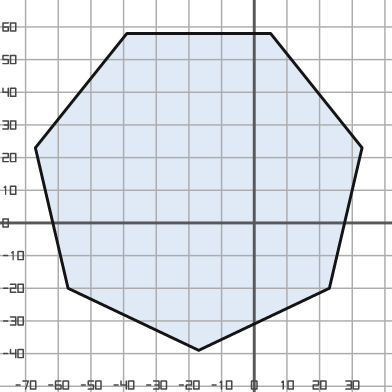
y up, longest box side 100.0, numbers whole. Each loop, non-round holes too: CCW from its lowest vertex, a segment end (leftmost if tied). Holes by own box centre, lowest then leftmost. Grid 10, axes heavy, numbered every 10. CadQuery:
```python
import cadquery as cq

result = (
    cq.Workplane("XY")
    .moveTo(-17.0, -39.0)
    .lineTo(23.0, -20.0)
    .lineTo(33.0, 23.0)
    .lineTo(5.0, 58.0)
    .lineTo(-39.0, 58.0)
    .lineTo(-67.0, 23.0)
    .lineTo(-57.0, -20.0)
    .close()
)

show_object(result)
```